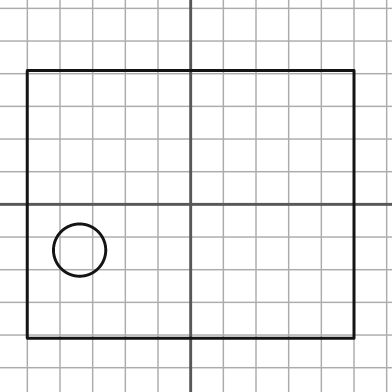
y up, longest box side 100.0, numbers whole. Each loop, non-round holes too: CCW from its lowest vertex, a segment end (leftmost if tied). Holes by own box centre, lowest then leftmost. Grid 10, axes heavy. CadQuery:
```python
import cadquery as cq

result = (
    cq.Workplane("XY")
    .moveTo(-50.0, -41.0)
    .lineTo(50.0, -41.0)
    .lineTo(50.0, 41.0)
    .lineTo(-50.0, 41.0)
    .close()
    .moveTo(-34.0, -14.0)
    .circle(8.0)
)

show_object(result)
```